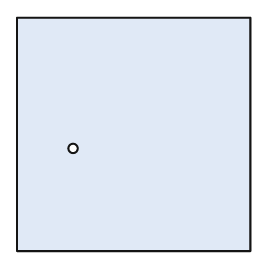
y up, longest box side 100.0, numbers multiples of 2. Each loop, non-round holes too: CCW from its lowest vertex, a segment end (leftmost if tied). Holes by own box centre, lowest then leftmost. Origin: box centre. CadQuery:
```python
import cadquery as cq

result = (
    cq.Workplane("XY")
    .moveTo(-50.0, -50.0)
    .lineTo(50.0, -50.0)
    .lineTo(50.0, 50.0)
    .lineTo(-50.0, 50.0)
    .close()
    .moveTo(-26.0, -6.0)
    .circle(2.0)
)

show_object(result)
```